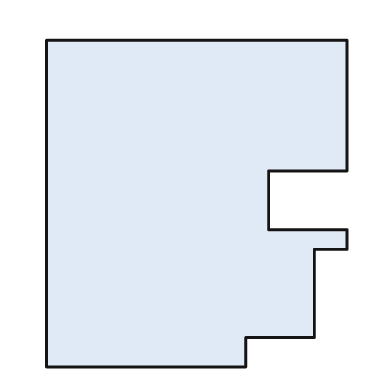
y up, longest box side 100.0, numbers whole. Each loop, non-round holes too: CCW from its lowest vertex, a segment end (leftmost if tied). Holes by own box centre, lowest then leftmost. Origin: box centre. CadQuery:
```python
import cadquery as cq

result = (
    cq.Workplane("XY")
    .moveTo(-46.0, -50.0)
    .lineTo(15.0, -50.0)
    .lineTo(15.0, -41.0)
    .lineTo(36.0, -41.0)
    .lineTo(36.0, -14.0)
    .lineTo(46.0, -14.0)
    .lineTo(46.0, -8.0)
    .lineTo(22.0, -8.0)
    .lineTo(22.0, 10.0)
    .lineTo(46.0, 10.0)
    .lineTo(46.0, 50.0)
    .lineTo(-46.0, 50.0)
    .close()
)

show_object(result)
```